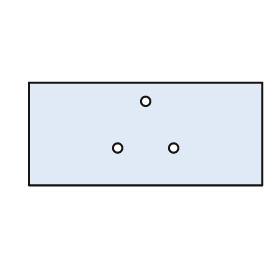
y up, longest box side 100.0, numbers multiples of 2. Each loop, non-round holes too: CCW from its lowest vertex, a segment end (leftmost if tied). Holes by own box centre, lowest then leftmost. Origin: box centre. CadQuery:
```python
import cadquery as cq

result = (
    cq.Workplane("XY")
    .moveTo(-50.0, -22.0)
    .lineTo(50.0, -22.0)
    .lineTo(50.0, 22.0)
    .lineTo(-50.0, 22.0)
    .close()
    .moveTo(-12.0, -6.0)
    .circle(2.0)
    .moveTo(12.0, -6.0)
    .circle(2.0)
    .moveTo(0.0, 14.0)
    .circle(2.0)
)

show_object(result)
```